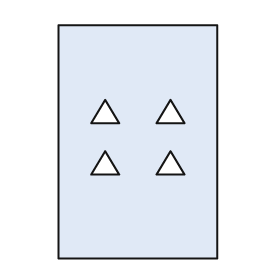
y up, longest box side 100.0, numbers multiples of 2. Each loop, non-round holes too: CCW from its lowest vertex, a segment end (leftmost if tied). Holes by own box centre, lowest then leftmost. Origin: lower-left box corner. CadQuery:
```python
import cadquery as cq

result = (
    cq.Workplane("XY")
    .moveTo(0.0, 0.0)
    .lineTo(68.0, 0.0)
    .lineTo(68.0, 100.0)
    .lineTo(0.0, 100.0)
    .close()
    .moveTo(14.0, 36.0)
    .lineTo(26.0, 36.0)
    .lineTo(20.0, 46.0)
    .close()
    .moveTo(42.0, 36.0)
    .lineTo(54.0, 36.0)
    .lineTo(48.0, 46.0)
    .close()
    .moveTo(14.0, 58.0)
    .lineTo(26.0, 58.0)
    .lineTo(20.0, 68.0)
    .close()
    .moveTo(42.0, 58.0)
    .lineTo(54.0, 58.0)
    .lineTo(48.0, 68.0)
    .close()
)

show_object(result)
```